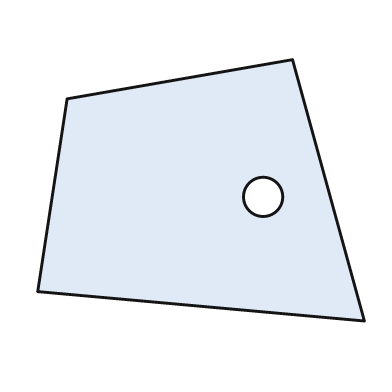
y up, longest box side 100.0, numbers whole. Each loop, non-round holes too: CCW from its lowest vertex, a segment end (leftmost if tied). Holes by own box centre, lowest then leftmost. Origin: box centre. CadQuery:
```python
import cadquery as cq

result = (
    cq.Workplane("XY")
    .moveTo(50.0, -40.0)
    .lineTo(28.0, 40.0)
    .lineTo(-41.0, 28.0)
    .lineTo(-50.0, -31.0)
    .close()
    .moveTo(19.0, -2.0)
    .circle(6.0)
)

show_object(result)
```